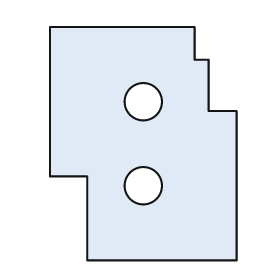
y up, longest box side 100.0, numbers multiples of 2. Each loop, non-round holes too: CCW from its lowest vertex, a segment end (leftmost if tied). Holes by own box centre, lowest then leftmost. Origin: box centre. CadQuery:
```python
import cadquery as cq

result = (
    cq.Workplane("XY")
    .moveTo(-24.0, -50.0)
    .lineTo(40.0, -50.0)
    .lineTo(40.0, 14.0)
    .lineTo(28.0, 14.0)
    .lineTo(28.0, 36.0)
    .lineTo(22.0, 36.0)
    .lineTo(22.0, 50.0)
    .lineTo(-40.0, 50.0)
    .lineTo(-40.0, -14.0)
    .lineTo(-24.0, -14.0)
    .close()
    .moveTo(0.0, -18.0)
    .circle(8.0)
    .moveTo(0.0, 18.0)
    .circle(8.0)
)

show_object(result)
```